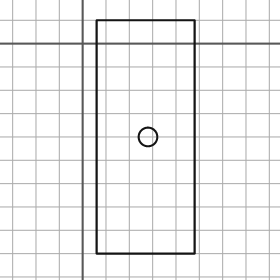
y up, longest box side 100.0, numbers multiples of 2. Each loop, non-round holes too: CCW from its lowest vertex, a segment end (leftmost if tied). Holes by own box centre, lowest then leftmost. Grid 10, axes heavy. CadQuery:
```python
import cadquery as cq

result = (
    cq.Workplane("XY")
    .moveTo(6.0, -90.0)
    .lineTo(48.0, -90.0)
    .lineTo(48.0, 10.0)
    .lineTo(6.0, 10.0)
    .close()
    .moveTo(28.0, -40.0)
    .circle(4.0)
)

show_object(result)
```